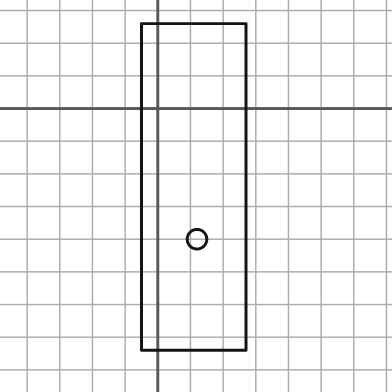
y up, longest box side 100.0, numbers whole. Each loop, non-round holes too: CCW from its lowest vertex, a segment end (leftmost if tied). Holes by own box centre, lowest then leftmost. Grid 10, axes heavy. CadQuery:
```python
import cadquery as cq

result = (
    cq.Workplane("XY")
    .moveTo(-5.0, -74.0)
    .lineTo(27.0, -74.0)
    .lineTo(27.0, 26.0)
    .lineTo(-5.0, 26.0)
    .close()
    .moveTo(12.0, -40.0)
    .circle(3.0)
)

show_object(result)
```